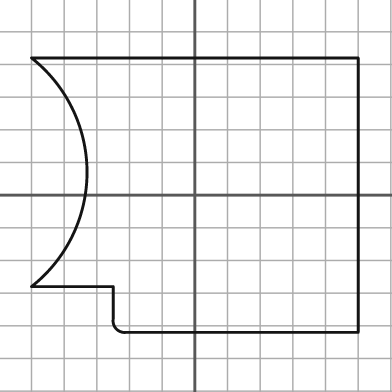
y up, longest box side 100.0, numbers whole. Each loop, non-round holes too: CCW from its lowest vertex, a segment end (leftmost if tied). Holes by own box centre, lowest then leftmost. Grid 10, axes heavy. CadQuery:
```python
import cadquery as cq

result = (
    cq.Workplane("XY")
    .moveTo(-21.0, -42.0)
    .lineTo(50.0, -42.0)
    .lineTo(50.0, 42.0)
    .lineTo(-50.0, 42.0)
    .threePointArc((-33.0, 7.0), (-50.0, -28.0))
    .lineTo(-25.0, -28.0)
    .lineTo(-25.0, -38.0)
    .threePointArc((-24.0, -41.0), (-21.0, -42.0))
    .close()
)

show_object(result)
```